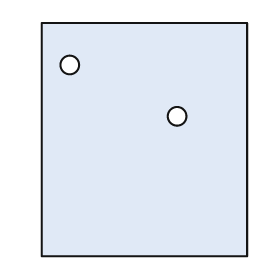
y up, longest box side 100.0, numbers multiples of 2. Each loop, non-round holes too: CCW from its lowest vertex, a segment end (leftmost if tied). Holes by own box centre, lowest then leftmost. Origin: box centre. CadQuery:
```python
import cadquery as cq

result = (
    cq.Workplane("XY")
    .moveTo(-44.0, -50.0)
    .lineTo(44.0, -50.0)
    .lineTo(44.0, 50.0)
    .lineTo(-44.0, 50.0)
    .close()
    .moveTo(14.0, 10.0)
    .circle(4.0)
    .moveTo(-32.0, 32.0)
    .circle(4.0)
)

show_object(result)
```